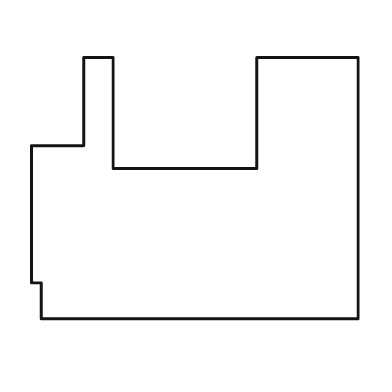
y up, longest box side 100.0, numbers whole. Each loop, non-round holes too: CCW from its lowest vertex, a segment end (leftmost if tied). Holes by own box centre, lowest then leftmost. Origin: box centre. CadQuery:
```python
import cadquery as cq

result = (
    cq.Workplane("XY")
    .moveTo(-47.0, -40.0)
    .lineTo(50.0, -40.0)
    .lineTo(50.0, 40.0)
    .lineTo(19.0, 40.0)
    .lineTo(19.0, 6.0)
    .lineTo(-25.0, 6.0)
    .lineTo(-25.0, 40.0)
    .lineTo(-34.0, 40.0)
    .lineTo(-34.0, 13.0)
    .lineTo(-50.0, 13.0)
    .lineTo(-50.0, -29.0)
    .lineTo(-47.0, -29.0)
    .close()
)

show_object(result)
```